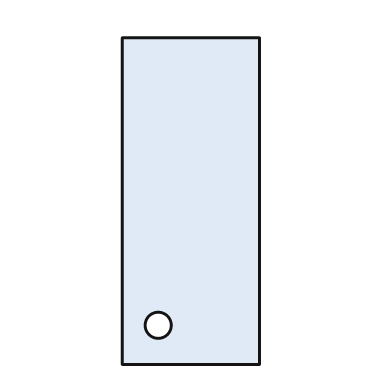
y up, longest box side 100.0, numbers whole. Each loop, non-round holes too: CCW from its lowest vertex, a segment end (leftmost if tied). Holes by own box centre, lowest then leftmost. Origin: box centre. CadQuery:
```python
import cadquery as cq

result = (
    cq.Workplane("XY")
    .moveTo(-21.0, -50.0)
    .lineTo(21.0, -50.0)
    .lineTo(21.0, 50.0)
    .lineTo(-21.0, 50.0)
    .close()
    .moveTo(-10.0, -38.0)
    .circle(4.0)
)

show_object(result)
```